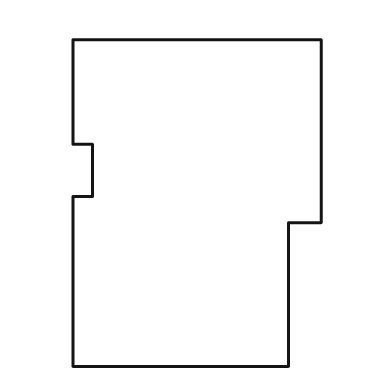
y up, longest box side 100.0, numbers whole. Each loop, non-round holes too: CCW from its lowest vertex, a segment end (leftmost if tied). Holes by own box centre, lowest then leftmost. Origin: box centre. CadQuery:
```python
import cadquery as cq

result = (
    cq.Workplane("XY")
    .moveTo(-38.0, -50.0)
    .lineTo(28.0, -50.0)
    .lineTo(28.0, -6.0)
    .lineTo(38.0, -6.0)
    .lineTo(38.0, 50.0)
    .lineTo(-38.0, 50.0)
    .lineTo(-38.0, 18.0)
    .lineTo(-32.0, 18.0)
    .lineTo(-32.0, 2.0)
    .lineTo(-38.0, 2.0)
    .close()
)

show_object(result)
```